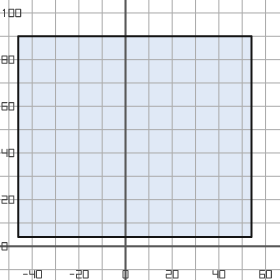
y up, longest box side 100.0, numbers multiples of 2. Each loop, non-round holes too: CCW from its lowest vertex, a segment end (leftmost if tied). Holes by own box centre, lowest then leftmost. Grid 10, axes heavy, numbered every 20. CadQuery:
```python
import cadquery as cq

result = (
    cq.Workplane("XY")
    .moveTo(-46.0, 4.0)
    .lineTo(54.0, 4.0)
    .lineTo(54.0, 90.0)
    .lineTo(-46.0, 90.0)
    .close()
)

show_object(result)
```